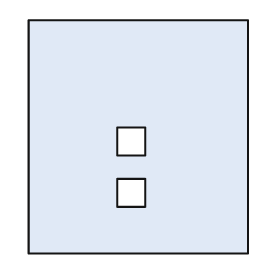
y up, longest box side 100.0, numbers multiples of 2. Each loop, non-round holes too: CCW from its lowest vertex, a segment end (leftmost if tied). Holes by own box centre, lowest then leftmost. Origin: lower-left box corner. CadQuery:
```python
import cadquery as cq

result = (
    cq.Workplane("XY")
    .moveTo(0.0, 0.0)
    .lineTo(94.0, 0.0)
    .lineTo(94.0, 100.0)
    .lineTo(0.0, 100.0)
    .close()
    .moveTo(38.0, 20.0)
    .lineTo(50.0, 20.0)
    .lineTo(50.0, 32.0)
    .lineTo(38.0, 32.0)
    .close()
    .moveTo(38.0, 42.0)
    .lineTo(50.0, 42.0)
    .lineTo(50.0, 54.0)
    .lineTo(38.0, 54.0)
    .close()
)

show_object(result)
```